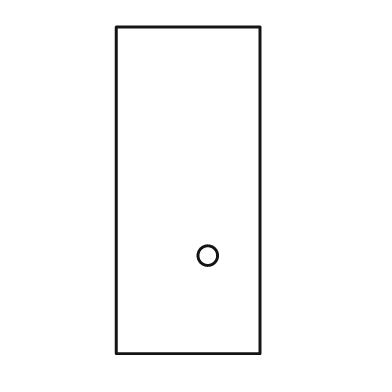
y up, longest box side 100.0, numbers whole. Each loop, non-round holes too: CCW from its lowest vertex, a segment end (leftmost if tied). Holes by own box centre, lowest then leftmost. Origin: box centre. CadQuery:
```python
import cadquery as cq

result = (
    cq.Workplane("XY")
    .moveTo(-22.0, -50.0)
    .lineTo(22.0, -50.0)
    .lineTo(22.0, 50.0)
    .lineTo(-22.0, 50.0)
    .close()
    .moveTo(6.0, -20.0)
    .circle(3.0)
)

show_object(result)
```